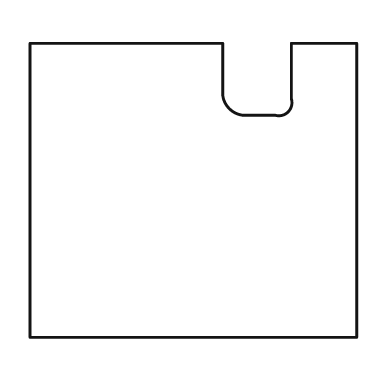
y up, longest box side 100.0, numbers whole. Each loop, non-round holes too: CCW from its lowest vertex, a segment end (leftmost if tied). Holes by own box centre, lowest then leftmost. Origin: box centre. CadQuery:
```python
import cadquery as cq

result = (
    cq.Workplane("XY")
    .moveTo(-50.0, -45.0)
    .lineTo(50.0, -45.0)
    .lineTo(50.0, 45.0)
    .lineTo(30.0, 45.0)
    .lineTo(30.0, 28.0)
    .threePointArc((29.0, 24.0), (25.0, 23.0))
    .lineTo(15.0, 23.0)
    .threePointArc((11.0, 25.0), (9.0, 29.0))
    .lineTo(9.0, 45.0)
    .lineTo(-50.0, 45.0)
    .close()
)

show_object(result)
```